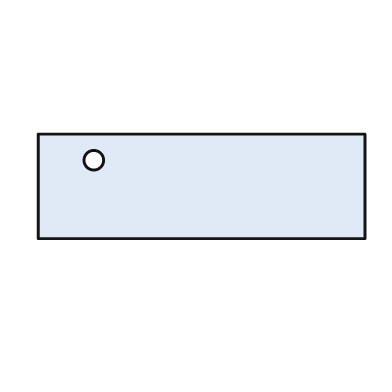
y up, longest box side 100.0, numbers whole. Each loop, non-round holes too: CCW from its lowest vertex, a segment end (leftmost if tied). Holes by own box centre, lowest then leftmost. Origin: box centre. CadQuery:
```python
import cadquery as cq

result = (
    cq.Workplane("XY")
    .moveTo(-50.0, -16.0)
    .lineTo(50.0, -16.0)
    .lineTo(50.0, 16.0)
    .lineTo(-50.0, 16.0)
    .close()
    .moveTo(-33.0, 8.0)
    .circle(3.0)
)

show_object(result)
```